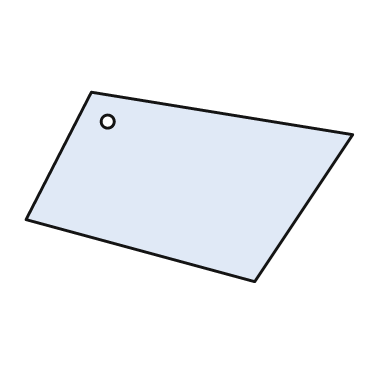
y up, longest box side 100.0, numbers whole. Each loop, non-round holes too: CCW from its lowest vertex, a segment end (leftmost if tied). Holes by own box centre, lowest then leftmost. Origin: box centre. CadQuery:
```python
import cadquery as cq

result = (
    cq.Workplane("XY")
    .moveTo(20.0, -29.0)
    .lineTo(50.0, 16.0)
    .lineTo(-30.0, 29.0)
    .lineTo(-50.0, -10.0)
    .close()
    .moveTo(-25.0, 20.0)
    .circle(2.0)
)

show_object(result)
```